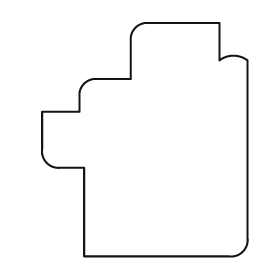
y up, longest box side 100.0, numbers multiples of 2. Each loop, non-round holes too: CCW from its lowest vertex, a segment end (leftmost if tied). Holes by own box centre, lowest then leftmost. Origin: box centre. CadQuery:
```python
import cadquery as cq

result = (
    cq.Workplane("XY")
    .moveTo(-26.0, -50.0)
    .lineTo(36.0, -50.0)
    .threePointArc((42.0, -48.0), (44.0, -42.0))
    .lineTo(44.0, 34.0)
    .threePointArc((38.0, 36.0), (32.0, 34.0))
    .lineTo(32.0, 50.0)
    .lineTo(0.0, 50.0)
    .threePointArc((-4.0, 48.0), (-6.0, 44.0))
    .lineTo(-6.0, 26.0)
    .lineTo(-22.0, 26.0)
    .threePointArc((-26.0, 24.0), (-28.0, 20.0))
    .lineTo(-28.0, 12.0)
    .lineTo(-44.0, 12.0)
    .lineTo(-44.0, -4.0)
    .threePointArc((-42.0, -10.0), (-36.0, -12.0))
    .lineTo(-26.0, -12.0)
    .close()
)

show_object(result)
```